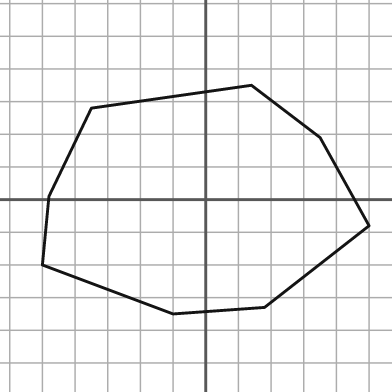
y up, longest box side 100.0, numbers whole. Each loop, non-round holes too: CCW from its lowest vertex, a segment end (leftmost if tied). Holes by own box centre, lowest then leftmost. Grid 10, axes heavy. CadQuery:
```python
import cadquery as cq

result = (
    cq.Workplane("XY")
    .moveTo(-10.0, -35.0)
    .lineTo(18.0, -33.0)
    .lineTo(50.0, -8.0)
    .lineTo(35.0, 19.0)
    .lineTo(14.0, 35.0)
    .lineTo(-35.0, 28.0)
    .lineTo(-48.0, 1.0)
    .lineTo(-50.0, -20.0)
    .close()
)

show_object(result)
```